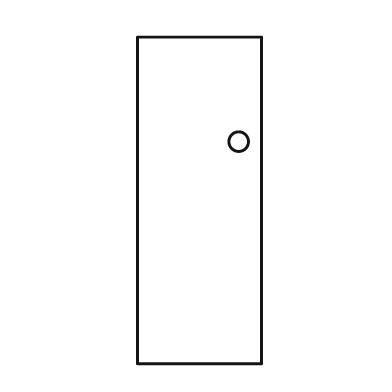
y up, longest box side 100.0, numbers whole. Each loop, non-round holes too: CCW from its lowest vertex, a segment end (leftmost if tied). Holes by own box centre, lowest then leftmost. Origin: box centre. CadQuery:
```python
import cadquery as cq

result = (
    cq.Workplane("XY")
    .moveTo(-19.0, -50.0)
    .lineTo(19.0, -50.0)
    .lineTo(19.0, 50.0)
    .lineTo(-19.0, 50.0)
    .close()
    .moveTo(12.0, 18.0)
    .circle(3.0)
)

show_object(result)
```